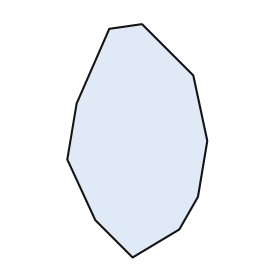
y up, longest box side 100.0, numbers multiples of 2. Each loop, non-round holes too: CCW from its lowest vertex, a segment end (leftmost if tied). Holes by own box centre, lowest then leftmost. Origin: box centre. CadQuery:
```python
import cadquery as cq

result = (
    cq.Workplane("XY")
    .moveTo(-2.0, -50.0)
    .lineTo(18.0, -38.0)
    .lineTo(26.0, -24.0)
    .lineTo(30.0, 0.0)
    .lineTo(24.0, 28.0)
    .lineTo(2.0, 50.0)
    .lineTo(-12.0, 48.0)
    .lineTo(-26.0, 16.0)
    .lineTo(-30.0, -8.0)
    .lineTo(-18.0, -34.0)
    .close()
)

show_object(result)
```